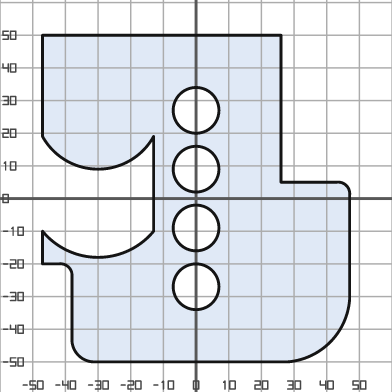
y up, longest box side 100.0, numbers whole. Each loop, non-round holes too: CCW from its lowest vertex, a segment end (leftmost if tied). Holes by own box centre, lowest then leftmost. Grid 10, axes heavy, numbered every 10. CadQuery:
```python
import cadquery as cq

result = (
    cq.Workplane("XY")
    .moveTo(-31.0, -50.0)
    .lineTo(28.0, -50.0)
    .threePointArc((41.0, -44.0), (47.0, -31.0))
    .lineTo(47.0, 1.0)
    .threePointArc((46.0, 4.0), (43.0, 5.0))
    .lineTo(26.0, 5.0)
    .lineTo(26.0, 50.0)
    .lineTo(-47.0, 50.0)
    .lineTo(-47.0, 19.0)
    .threePointArc((-30.0, 9.0), (-13.0, 19.0))
    .lineTo(-13.0, -10.0)
    .threePointArc((-30.0, -18.0), (-47.0, -10.0))
    .lineTo(-47.0, -20.0)
    .lineTo(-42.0, -20.0)
    .threePointArc((-39.0, -21.0), (-38.0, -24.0))
    .lineTo(-38.0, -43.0)
    .threePointArc((-36.0, -48.0), (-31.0, -50.0))
    .close()
    .moveTo(0.0, -27.0)
    .circle(7.0)
    .moveTo(0.0, -9.0)
    .circle(7.0)
    .moveTo(0.0, 9.0)
    .circle(7.0)
    .moveTo(0.0, 27.0)
    .circle(7.0)
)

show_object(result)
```